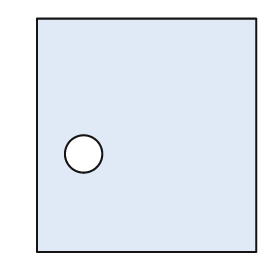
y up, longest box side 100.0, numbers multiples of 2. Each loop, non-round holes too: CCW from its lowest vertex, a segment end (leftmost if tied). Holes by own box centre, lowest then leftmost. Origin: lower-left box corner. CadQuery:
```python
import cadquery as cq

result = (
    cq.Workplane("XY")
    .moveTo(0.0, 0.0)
    .lineTo(94.0, 0.0)
    .lineTo(94.0, 100.0)
    .lineTo(0.0, 100.0)
    .close()
    .moveTo(20.0, 42.0)
    .circle(8.0)
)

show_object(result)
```